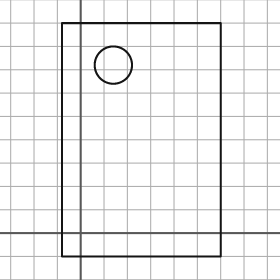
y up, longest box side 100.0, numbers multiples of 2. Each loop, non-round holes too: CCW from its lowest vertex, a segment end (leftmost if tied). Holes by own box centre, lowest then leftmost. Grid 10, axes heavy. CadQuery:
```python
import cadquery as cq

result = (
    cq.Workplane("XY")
    .moveTo(-8.0, -10.0)
    .lineTo(60.0, -10.0)
    .lineTo(60.0, 90.0)
    .lineTo(-8.0, 90.0)
    .close()
    .moveTo(14.0, 72.0)
    .circle(8.0)
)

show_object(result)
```